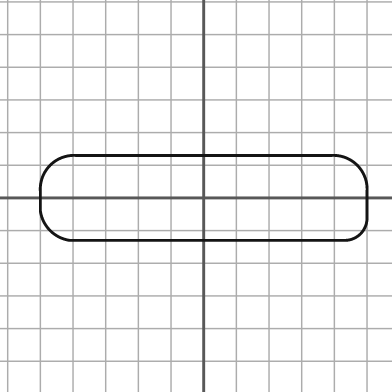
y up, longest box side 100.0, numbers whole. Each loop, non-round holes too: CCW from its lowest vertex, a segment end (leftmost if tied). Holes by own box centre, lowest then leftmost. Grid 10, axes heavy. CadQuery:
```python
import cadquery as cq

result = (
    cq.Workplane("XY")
    .moveTo(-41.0, -13.0)
    .lineTo(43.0, -13.0)
    .threePointArc((48.0, -11.0), (50.0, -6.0))
    .lineTo(50.0, 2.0)
    .threePointArc((47.0, 10.0), (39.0, 13.0))
    .lineTo(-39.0, 13.0)
    .threePointArc((-47.0, 10.0), (-50.0, 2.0))
    .lineTo(-50.0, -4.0)
    .threePointArc((-47.0, -10.0), (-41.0, -13.0))
    .close()
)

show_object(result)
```